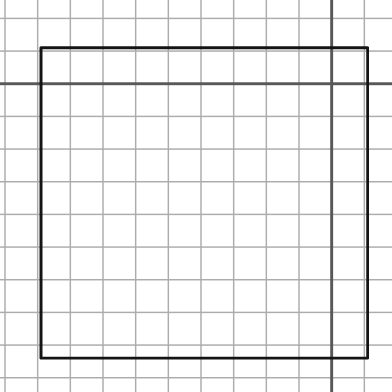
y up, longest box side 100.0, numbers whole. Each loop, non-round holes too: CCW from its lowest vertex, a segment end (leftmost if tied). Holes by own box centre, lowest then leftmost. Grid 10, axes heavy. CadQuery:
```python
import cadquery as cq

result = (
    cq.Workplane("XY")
    .moveTo(-89.0, -84.0)
    .lineTo(11.0, -84.0)
    .lineTo(11.0, 11.0)
    .lineTo(-89.0, 11.0)
    .close()
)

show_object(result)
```